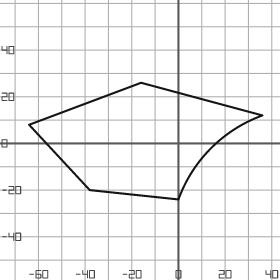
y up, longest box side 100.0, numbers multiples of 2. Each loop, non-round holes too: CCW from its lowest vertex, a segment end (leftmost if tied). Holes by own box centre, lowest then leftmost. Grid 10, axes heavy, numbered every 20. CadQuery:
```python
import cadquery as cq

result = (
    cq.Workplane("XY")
    .moveTo(0.0, -24.0)
    .threePointArc((14.0, -2.0), (36.0, 12.0))
    .lineTo(-16.0, 26.0)
    .lineTo(-64.0, 8.0)
    .lineTo(-38.0, -20.0)
    .close()
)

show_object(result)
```